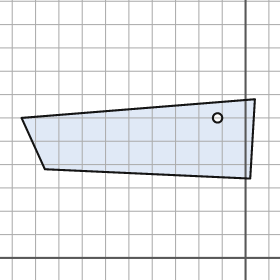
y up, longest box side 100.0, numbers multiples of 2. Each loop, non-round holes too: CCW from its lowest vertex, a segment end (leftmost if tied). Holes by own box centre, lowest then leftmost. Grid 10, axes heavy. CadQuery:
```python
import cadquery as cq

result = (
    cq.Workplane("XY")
    .moveTo(2.0, 34.0)
    .lineTo(4.0, 68.0)
    .lineTo(-96.0, 60.0)
    .lineTo(-86.0, 38.0)
    .close()
    .moveTo(-12.0, 60.0)
    .circle(2.0)
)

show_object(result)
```